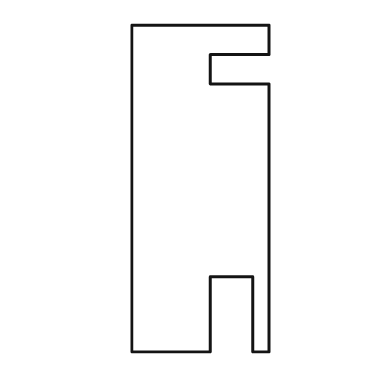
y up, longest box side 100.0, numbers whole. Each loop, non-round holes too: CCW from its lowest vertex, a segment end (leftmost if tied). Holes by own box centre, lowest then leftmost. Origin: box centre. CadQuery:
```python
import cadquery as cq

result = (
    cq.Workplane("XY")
    .moveTo(-21.0, -50.0)
    .lineTo(3.0, -50.0)
    .lineTo(3.0, -27.0)
    .lineTo(16.0, -27.0)
    .lineTo(16.0, -50.0)
    .lineTo(21.0, -50.0)
    .lineTo(21.0, 32.0)
    .lineTo(3.0, 32.0)
    .lineTo(3.0, 41.0)
    .lineTo(21.0, 41.0)
    .lineTo(21.0, 50.0)
    .lineTo(-21.0, 50.0)
    .close()
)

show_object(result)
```